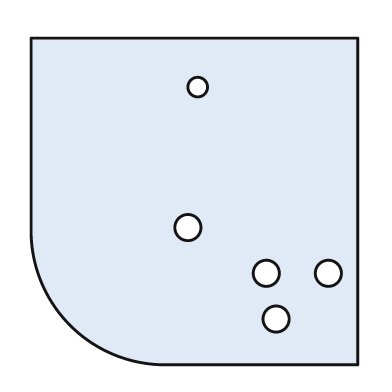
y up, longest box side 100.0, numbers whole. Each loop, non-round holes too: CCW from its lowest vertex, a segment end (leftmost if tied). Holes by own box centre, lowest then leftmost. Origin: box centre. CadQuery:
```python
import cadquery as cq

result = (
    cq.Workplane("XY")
    .moveTo(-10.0, -50.0)
    .lineTo(50.0, -50.0)
    .lineTo(50.0, 50.0)
    .lineTo(-50.0, 50.0)
    .lineTo(-50.0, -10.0)
    .threePointArc((-38.0, -38.0), (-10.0, -50.0))
    .close()
    .moveTo(25.0, -36.0)
    .circle(4.0)
    .moveTo(22.0, -22.0)
    .circle(4.0)
    .moveTo(41.0, -22.0)
    .circle(4.0)
    .moveTo(-2.0, -8.0)
    .circle(4.0)
    .moveTo(1.0, 35.0)
    .circle(3.0)
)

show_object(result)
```